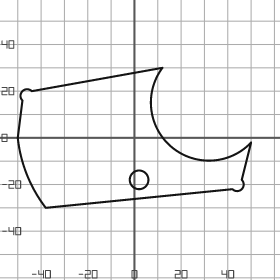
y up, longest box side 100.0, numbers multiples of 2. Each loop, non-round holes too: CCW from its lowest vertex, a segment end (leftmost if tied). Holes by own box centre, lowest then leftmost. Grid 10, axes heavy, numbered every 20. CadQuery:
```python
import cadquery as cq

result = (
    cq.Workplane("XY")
    .moveTo(-38.0, -30.0)
    .lineTo(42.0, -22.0)
    .threePointArc((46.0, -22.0), (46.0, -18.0))
    .lineTo(50.0, -2.0)
    .threePointArc((16.0, -4.0), (12.0, 30.0))
    .lineTo(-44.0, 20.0)
    .threePointArc((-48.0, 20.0), (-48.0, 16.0))
    .lineTo(-50.0, 0.0)
    .threePointArc((-46.0, -16.0), (-38.0, -30.0))
    .close()
    .moveTo(2.0, -18.0)
    .circle(4.0)
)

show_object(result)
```